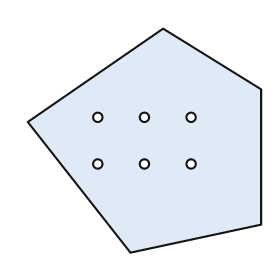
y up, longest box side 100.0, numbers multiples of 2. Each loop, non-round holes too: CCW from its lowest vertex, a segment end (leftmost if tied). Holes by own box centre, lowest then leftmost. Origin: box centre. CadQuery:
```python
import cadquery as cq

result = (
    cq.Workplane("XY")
    .moveTo(-6.0, -48.0)
    .lineTo(50.0, -36.0)
    .lineTo(50.0, 22.0)
    .lineTo(8.0, 48.0)
    .lineTo(-50.0, 8.0)
    .close()
    .moveTo(-20.0, -10.0)
    .circle(2.0)
    .moveTo(0.0, -10.0)
    .circle(2.0)
    .moveTo(20.0, -10.0)
    .circle(2.0)
    .moveTo(-20.0, 10.0)
    .circle(2.0)
    .moveTo(0.0, 10.0)
    .circle(2.0)
    .moveTo(20.0, 10.0)
    .circle(2.0)
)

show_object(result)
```